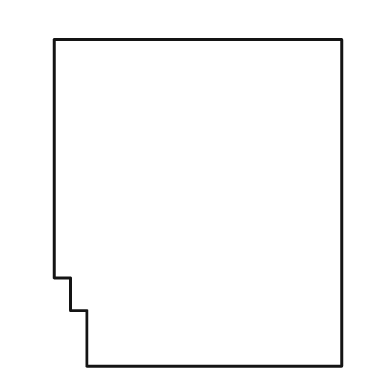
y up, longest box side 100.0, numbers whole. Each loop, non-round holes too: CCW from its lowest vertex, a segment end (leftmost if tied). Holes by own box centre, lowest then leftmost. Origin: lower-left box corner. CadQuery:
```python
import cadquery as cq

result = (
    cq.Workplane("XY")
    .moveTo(10.0, 0.0)
    .lineTo(88.0, 0.0)
    .lineTo(88.0, 100.0)
    .lineTo(0.0, 100.0)
    .lineTo(0.0, 27.0)
    .lineTo(5.0, 27.0)
    .lineTo(5.0, 17.0)
    .lineTo(10.0, 17.0)
    .close()
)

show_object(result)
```